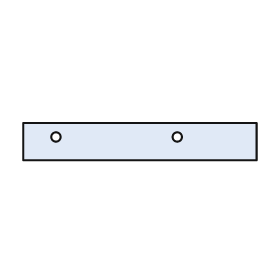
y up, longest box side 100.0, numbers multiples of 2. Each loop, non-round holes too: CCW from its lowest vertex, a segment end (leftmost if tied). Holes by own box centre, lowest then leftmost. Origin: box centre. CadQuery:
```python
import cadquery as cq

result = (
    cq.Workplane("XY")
    .moveTo(-50.0, -8.0)
    .lineTo(50.0, -8.0)
    .lineTo(50.0, 8.0)
    .lineTo(-50.0, 8.0)
    .close()
    .moveTo(-36.0, 2.0)
    .circle(2.0)
    .moveTo(16.0, 2.0)
    .circle(2.0)
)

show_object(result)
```